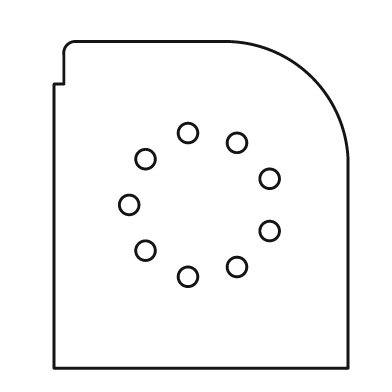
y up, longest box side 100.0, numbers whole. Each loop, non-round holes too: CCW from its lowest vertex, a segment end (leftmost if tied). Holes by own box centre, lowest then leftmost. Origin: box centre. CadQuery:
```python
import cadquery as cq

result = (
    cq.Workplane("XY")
    .moveTo(-45.0, -50.0)
    .lineTo(45.0, -50.0)
    .lineTo(45.0, 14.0)
    .threePointArc((34.0, 39.0), (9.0, 50.0))
    .lineTo(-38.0, 50.0)
    .threePointArc((-41.0, 49.0), (-42.0, 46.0))
    .lineTo(-42.0, 37.0)
    .lineTo(-45.0, 37.0)
    .close()
    .moveTo(-4.0, -22.0)
    .circle(3.0)
    .moveTo(11.0, -19.0)
    .circle(3.0)
    .moveTo(-17.0, -14.0)
    .circle(3.0)
    .moveTo(21.0, -8.0)
    .circle(3.0)
    .moveTo(-22.0, 0.0)
    .circle(3.0)
    .moveTo(21.0, 8.0)
    .circle(3.0)
    .moveTo(-17.0, 14.0)
    .circle(3.0)
    .moveTo(11.0, 19.0)
    .circle(3.0)
    .moveTo(-4.0, 22.0)
    .circle(3.0)
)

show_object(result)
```